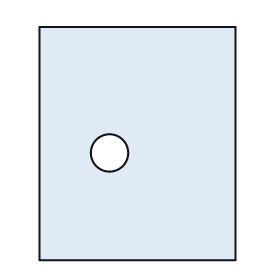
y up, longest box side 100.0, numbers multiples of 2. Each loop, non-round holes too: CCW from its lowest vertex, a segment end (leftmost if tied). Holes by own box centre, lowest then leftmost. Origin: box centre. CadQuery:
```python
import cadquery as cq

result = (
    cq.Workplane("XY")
    .moveTo(-42.0, -50.0)
    .lineTo(42.0, -50.0)
    .lineTo(42.0, 50.0)
    .lineTo(-42.0, 50.0)
    .close()
    .moveTo(-12.0, -4.0)
    .circle(8.0)
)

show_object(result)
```